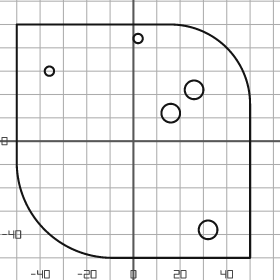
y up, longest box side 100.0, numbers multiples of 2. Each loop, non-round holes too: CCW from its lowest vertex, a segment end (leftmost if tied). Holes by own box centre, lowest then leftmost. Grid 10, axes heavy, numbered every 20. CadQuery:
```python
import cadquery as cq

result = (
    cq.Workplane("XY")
    .moveTo(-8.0, -50.0)
    .lineTo(50.0, -50.0)
    .lineTo(50.0, 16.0)
    .threePointArc((40.0, 40.0), (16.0, 50.0))
    .lineTo(-50.0, 50.0)
    .lineTo(-50.0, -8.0)
    .threePointArc((-38.0, -38.0), (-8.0, -50.0))
    .close()
    .moveTo(32.0, -38.0)
    .circle(4.0)
    .moveTo(16.0, 12.0)
    .circle(4.0)
    .moveTo(26.0, 22.0)
    .circle(4.0)
    .moveTo(-36.0, 30.0)
    .circle(2.0)
    .moveTo(2.0, 44.0)
    .circle(2.0)
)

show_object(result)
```